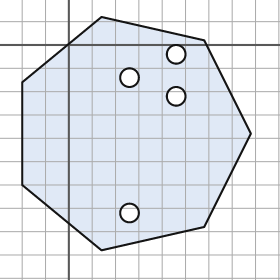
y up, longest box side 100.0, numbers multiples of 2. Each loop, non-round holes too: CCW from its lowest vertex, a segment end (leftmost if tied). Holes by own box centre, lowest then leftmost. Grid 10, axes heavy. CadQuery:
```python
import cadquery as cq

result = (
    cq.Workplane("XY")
    .moveTo(14.0, -88.0)
    .lineTo(58.0, -78.0)
    .lineTo(78.0, -38.0)
    .lineTo(58.0, 2.0)
    .lineTo(14.0, 12.0)
    .lineTo(-20.0, -16.0)
    .lineTo(-20.0, -60.0)
    .close()
    .moveTo(26.0, -72.0)
    .circle(4.0)
    .moveTo(46.0, -22.0)
    .circle(4.0)
    .moveTo(26.0, -14.0)
    .circle(4.0)
    .moveTo(46.0, -4.0)
    .circle(4.0)
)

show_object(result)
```